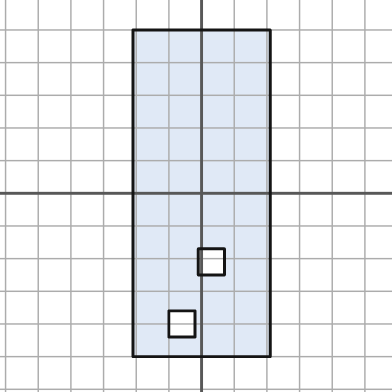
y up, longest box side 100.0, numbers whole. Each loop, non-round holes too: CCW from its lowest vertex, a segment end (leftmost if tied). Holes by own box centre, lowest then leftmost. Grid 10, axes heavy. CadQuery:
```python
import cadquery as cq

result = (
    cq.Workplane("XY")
    .moveTo(-21.0, -50.0)
    .lineTo(21.0, -50.0)
    .lineTo(21.0, 50.0)
    .lineTo(-21.0, 50.0)
    .close()
    .moveTo(-10.0, -44.0)
    .lineTo(-2.0, -44.0)
    .lineTo(-2.0, -36.0)
    .lineTo(-10.0, -36.0)
    .close()
    .moveTo(-1.0, -25.0)
    .lineTo(7.0, -25.0)
    .lineTo(7.0, -17.0)
    .lineTo(-1.0, -17.0)
    .close()
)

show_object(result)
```